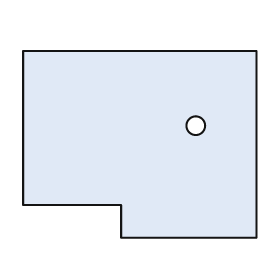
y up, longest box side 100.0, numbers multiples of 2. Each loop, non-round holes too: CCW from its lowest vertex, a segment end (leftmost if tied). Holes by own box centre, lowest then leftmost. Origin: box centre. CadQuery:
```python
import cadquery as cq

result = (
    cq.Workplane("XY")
    .moveTo(-8.0, -40.0)
    .lineTo(50.0, -40.0)
    .lineTo(50.0, 40.0)
    .lineTo(-50.0, 40.0)
    .lineTo(-50.0, -26.0)
    .lineTo(-8.0, -26.0)
    .close()
    .moveTo(24.0, 8.0)
    .circle(4.0)
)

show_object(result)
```